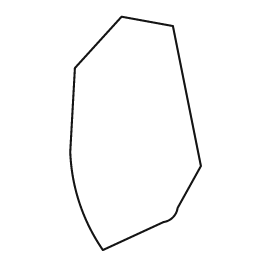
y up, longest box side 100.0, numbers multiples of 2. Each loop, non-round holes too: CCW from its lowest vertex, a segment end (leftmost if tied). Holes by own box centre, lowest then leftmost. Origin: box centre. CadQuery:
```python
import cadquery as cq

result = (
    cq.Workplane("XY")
    .moveTo(-14.0, -50.0)
    .lineTo(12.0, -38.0)
    .threePointArc((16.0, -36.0), (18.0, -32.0))
    .lineTo(28.0, -14.0)
    .lineTo(16.0, 46.0)
    .lineTo(-6.0, 50.0)
    .lineTo(-26.0, 28.0)
    .lineTo(-28.0, -8.0)
    .threePointArc((-24.0, -30.0), (-14.0, -50.0))
    .close()
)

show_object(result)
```